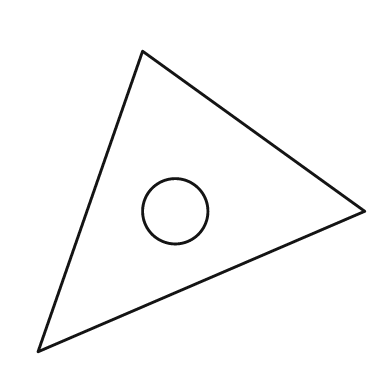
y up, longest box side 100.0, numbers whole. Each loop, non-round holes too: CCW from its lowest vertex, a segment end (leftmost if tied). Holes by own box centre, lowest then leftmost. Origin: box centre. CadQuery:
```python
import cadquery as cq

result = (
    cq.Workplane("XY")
    .moveTo(-50.0, -46.0)
    .lineTo(50.0, -3.0)
    .lineTo(-18.0, 46.0)
    .close()
    .moveTo(-8.0, -3.0)
    .circle(10.0)
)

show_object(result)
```